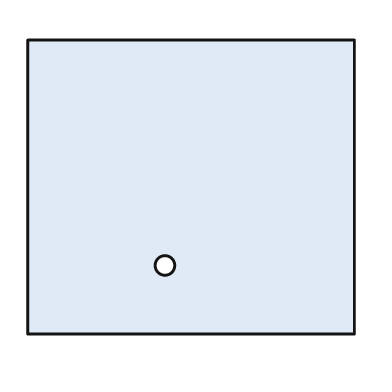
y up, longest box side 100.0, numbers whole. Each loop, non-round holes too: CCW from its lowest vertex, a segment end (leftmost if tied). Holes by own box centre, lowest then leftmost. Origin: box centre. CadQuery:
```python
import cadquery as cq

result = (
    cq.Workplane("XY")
    .moveTo(-50.0, -45.0)
    .lineTo(50.0, -45.0)
    .lineTo(50.0, 45.0)
    .lineTo(-50.0, 45.0)
    .close()
    .moveTo(-8.0, -24.0)
    .circle(3.0)
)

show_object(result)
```